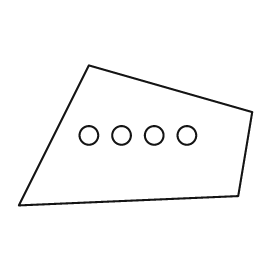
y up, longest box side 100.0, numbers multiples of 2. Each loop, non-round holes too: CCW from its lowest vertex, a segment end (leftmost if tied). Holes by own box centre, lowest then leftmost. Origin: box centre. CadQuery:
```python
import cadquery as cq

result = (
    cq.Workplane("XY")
    .moveTo(-50.0, -30.0)
    .lineTo(44.0, -26.0)
    .lineTo(50.0, 10.0)
    .lineTo(-20.0, 30.0)
    .close()
    .moveTo(-20.0, 0.0)
    .circle(4.0)
    .moveTo(-6.0, 0.0)
    .circle(4.0)
    .moveTo(8.0, 0.0)
    .circle(4.0)
    .moveTo(22.0, 0.0)
    .circle(4.0)
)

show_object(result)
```